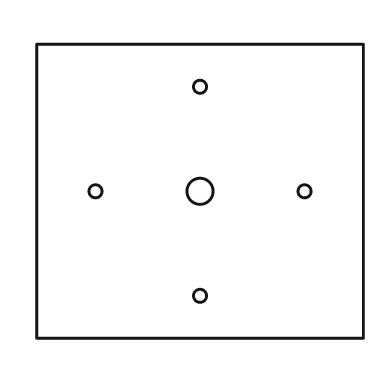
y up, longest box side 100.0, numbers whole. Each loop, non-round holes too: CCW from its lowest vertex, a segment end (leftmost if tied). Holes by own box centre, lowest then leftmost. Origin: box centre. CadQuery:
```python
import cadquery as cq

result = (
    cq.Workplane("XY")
    .moveTo(-50.0, -45.0)
    .lineTo(50.0, -45.0)
    .lineTo(50.0, 45.0)
    .lineTo(-50.0, 45.0)
    .close()
    .moveTo(0.0, -32.0)
    .circle(2.0)
    .moveTo(-32.0, 0.0)
    .circle(2.0)
    .moveTo(0.0, 0.0)
    .circle(4.0)
    .moveTo(32.0, 0.0)
    .circle(2.0)
    .moveTo(0.0, 32.0)
    .circle(2.0)
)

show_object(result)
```